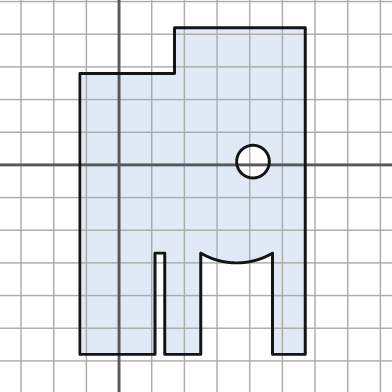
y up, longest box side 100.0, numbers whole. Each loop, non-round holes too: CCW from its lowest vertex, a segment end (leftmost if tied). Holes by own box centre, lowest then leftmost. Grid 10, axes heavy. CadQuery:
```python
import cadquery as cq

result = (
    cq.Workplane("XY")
    .moveTo(-12.0, -58.0)
    .lineTo(11.0, -58.0)
    .lineTo(11.0, -27.0)
    .lineTo(14.0, -27.0)
    .lineTo(14.0, -58.0)
    .lineTo(25.0, -58.0)
    .lineTo(25.0, -27.0)
    .threePointArc((36.0, -30.0), (47.0, -27.0))
    .lineTo(47.0, -58.0)
    .lineTo(57.0, -58.0)
    .lineTo(57.0, 42.0)
    .lineTo(17.0, 42.0)
    .lineTo(17.0, 28.0)
    .lineTo(-12.0, 28.0)
    .close()
    .moveTo(41.0, 1.0)
    .circle(5.0)
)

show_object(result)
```